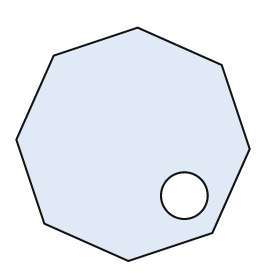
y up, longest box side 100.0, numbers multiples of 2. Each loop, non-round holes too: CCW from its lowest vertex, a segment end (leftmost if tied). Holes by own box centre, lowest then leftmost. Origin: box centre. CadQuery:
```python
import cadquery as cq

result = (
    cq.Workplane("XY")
    .moveTo(-2.0, -50.0)
    .lineTo(34.0, -38.0)
    .lineTo(50.0, -2.0)
    .lineTo(38.0, 34.0)
    .lineTo(2.0, 50.0)
    .lineTo(-34.0, 38.0)
    .lineTo(-50.0, 2.0)
    .lineTo(-38.0, -34.0)
    .close()
    .moveTo(22.0, -22.0)
    .circle(10.0)
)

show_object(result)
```